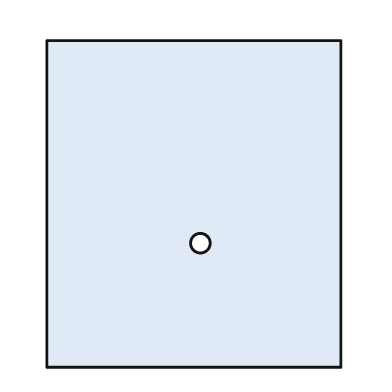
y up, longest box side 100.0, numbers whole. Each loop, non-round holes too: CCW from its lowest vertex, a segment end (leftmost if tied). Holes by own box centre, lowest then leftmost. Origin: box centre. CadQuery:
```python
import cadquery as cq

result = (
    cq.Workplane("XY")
    .moveTo(-45.0, -50.0)
    .lineTo(45.0, -50.0)
    .lineTo(45.0, 50.0)
    .lineTo(-45.0, 50.0)
    .close()
    .moveTo(2.0, -12.0)
    .circle(3.0)
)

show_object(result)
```